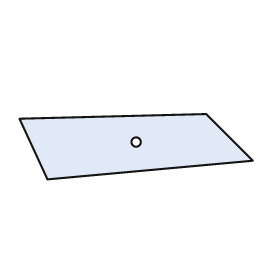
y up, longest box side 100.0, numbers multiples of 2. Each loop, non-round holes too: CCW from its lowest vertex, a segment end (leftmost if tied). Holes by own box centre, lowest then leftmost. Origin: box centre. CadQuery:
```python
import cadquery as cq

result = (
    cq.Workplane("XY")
    .moveTo(-38.0, -14.0)
    .lineTo(50.0, -6.0)
    .lineTo(30.0, 14.0)
    .lineTo(-50.0, 12.0)
    .close()
    .moveTo(0.0, 2.0)
    .circle(2.0)
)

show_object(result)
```